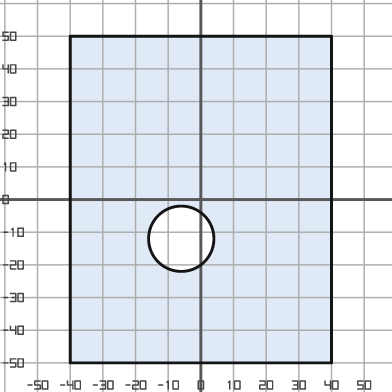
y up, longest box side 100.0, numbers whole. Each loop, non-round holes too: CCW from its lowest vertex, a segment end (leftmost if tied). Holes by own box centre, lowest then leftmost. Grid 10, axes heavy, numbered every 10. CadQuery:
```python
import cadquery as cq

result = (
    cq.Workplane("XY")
    .moveTo(-40.0, -50.0)
    .lineTo(40.0, -50.0)
    .lineTo(40.0, 50.0)
    .lineTo(-40.0, 50.0)
    .close()
    .moveTo(-6.0, -12.0)
    .circle(10.0)
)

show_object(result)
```